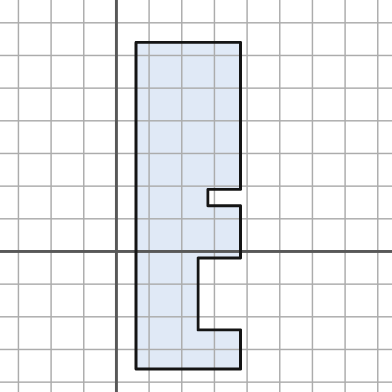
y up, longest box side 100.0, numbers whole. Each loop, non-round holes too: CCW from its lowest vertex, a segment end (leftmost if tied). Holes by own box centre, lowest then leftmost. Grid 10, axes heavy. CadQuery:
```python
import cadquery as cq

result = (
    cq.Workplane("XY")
    .moveTo(6.0, -36.0)
    .lineTo(38.0, -36.0)
    .lineTo(38.0, -24.0)
    .lineTo(25.0, -24.0)
    .lineTo(25.0, -2.0)
    .lineTo(38.0, -2.0)
    .lineTo(38.0, 14.0)
    .lineTo(28.0, 14.0)
    .lineTo(28.0, 19.0)
    .lineTo(38.0, 19.0)
    .lineTo(38.0, 64.0)
    .lineTo(6.0, 64.0)
    .close()
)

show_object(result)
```